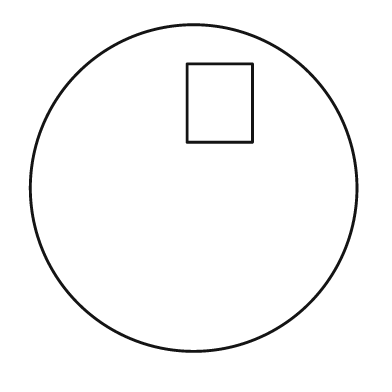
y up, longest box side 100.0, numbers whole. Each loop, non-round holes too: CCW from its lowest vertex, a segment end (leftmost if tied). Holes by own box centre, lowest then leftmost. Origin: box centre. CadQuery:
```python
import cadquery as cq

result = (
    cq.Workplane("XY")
    .moveTo(0.0, 0.0)
    .circle(50.0)
    .moveTo(-2.0, 14.0)
    .lineTo(18.0, 14.0)
    .lineTo(18.0, 38.0)
    .lineTo(-2.0, 38.0)
    .close()
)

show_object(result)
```